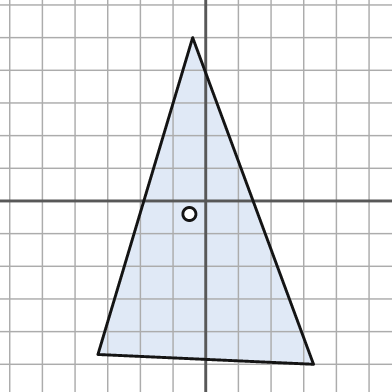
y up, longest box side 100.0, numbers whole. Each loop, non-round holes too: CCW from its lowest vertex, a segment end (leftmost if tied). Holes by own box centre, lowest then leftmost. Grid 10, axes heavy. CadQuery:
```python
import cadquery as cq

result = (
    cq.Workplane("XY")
    .moveTo(33.0, -50.0)
    .lineTo(-4.0, 50.0)
    .lineTo(-33.0, -47.0)
    .close()
    .moveTo(-5.0, -4.0)
    .circle(2.0)
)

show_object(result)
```